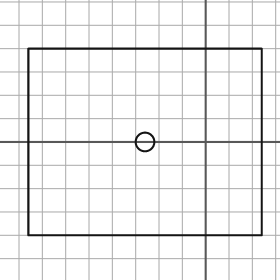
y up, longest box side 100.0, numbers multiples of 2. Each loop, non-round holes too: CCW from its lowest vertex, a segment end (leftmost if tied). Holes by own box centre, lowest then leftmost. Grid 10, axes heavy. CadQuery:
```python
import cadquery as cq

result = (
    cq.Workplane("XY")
    .moveTo(-76.0, -40.0)
    .lineTo(24.0, -40.0)
    .lineTo(24.0, 40.0)
    .lineTo(-76.0, 40.0)
    .close()
    .moveTo(-26.0, 0.0)
    .circle(4.0)
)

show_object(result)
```